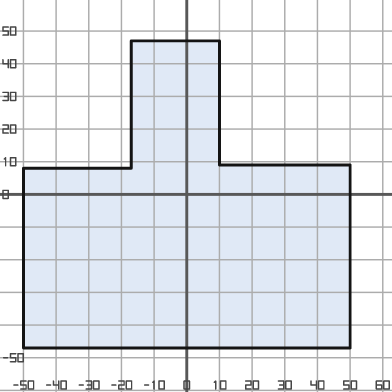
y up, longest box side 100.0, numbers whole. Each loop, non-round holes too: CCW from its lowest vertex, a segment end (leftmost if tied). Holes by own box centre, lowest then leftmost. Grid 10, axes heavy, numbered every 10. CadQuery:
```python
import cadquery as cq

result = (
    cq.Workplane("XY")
    .moveTo(-50.0, -47.0)
    .lineTo(50.0, -47.0)
    .lineTo(50.0, 9.0)
    .lineTo(10.0, 9.0)
    .lineTo(10.0, 47.0)
    .lineTo(-17.0, 47.0)
    .lineTo(-17.0, 8.0)
    .lineTo(-50.0, 8.0)
    .close()
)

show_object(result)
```